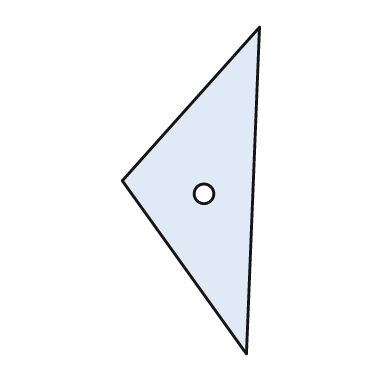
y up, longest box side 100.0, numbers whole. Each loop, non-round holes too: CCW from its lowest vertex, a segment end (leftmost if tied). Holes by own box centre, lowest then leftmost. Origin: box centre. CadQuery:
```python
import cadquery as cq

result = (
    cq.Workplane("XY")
    .moveTo(17.0, -50.0)
    .lineTo(21.0, 50.0)
    .lineTo(-21.0, 3.0)
    .close()
    .moveTo(4.0, -1.0)
    .circle(3.0)
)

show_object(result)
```